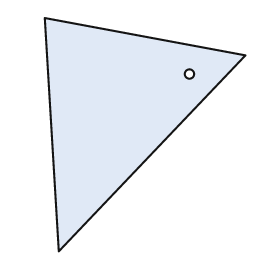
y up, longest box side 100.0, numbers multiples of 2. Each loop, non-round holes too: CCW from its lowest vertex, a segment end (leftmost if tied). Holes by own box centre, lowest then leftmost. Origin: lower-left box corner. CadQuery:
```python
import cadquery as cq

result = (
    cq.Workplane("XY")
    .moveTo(6.0, 0.0)
    .lineTo(86.0, 84.0)
    .lineTo(0.0, 100.0)
    .close()
    .moveTo(62.0, 76.0)
    .circle(2.0)
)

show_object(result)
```